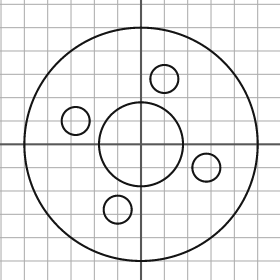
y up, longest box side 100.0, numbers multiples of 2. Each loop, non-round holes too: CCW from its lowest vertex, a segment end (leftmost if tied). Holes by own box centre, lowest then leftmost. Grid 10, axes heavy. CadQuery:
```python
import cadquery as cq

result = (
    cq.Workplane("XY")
    .moveTo(0.0, 0.0)
    .circle(50.0)
    .moveTo(-10.0, -28.0)
    .circle(6.0)
    .moveTo(28.0, -10.0)
    .circle(6.0)
    .moveTo(0.0, 0.0)
    .circle(18.0)
    .moveTo(-28.0, 10.0)
    .circle(6.0)
    .moveTo(10.0, 28.0)
    .circle(6.0)
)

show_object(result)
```